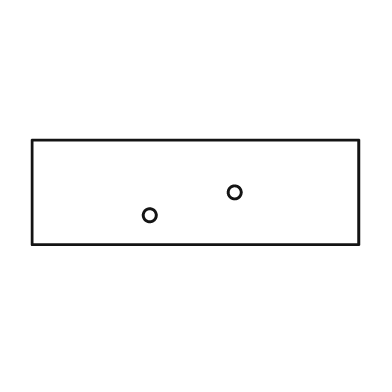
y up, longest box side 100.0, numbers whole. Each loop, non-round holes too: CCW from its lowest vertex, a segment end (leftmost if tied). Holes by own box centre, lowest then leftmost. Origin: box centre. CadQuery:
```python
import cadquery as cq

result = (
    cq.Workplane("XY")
    .moveTo(-50.0, -16.0)
    .lineTo(50.0, -16.0)
    .lineTo(50.0, 16.0)
    .lineTo(-50.0, 16.0)
    .close()
    .moveTo(-14.0, -7.0)
    .circle(2.0)
    .moveTo(12.0, 0.0)
    .circle(2.0)
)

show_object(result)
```